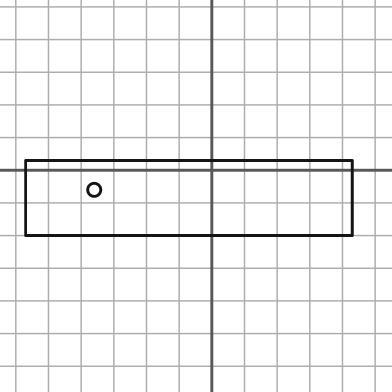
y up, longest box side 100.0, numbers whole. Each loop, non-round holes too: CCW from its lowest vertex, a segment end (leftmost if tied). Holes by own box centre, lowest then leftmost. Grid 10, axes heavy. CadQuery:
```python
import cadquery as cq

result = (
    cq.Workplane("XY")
    .moveTo(-57.0, -20.0)
    .lineTo(43.0, -20.0)
    .lineTo(43.0, 3.0)
    .lineTo(-57.0, 3.0)
    .close()
    .moveTo(-36.0, -6.0)
    .circle(2.0)
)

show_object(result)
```